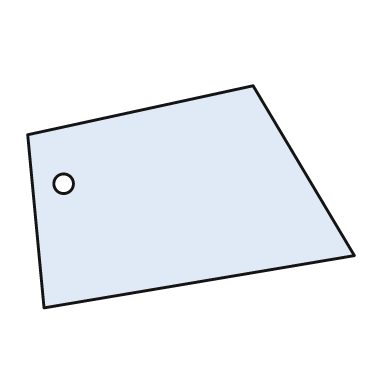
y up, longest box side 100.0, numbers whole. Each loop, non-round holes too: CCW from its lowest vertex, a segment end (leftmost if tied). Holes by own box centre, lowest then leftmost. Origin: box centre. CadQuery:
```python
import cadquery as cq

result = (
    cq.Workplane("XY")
    .moveTo(-45.0, -34.0)
    .lineTo(50.0, -18.0)
    .lineTo(19.0, 34.0)
    .lineTo(-50.0, 19.0)
    .close()
    .moveTo(-39.0, 4.0)
    .circle(3.0)
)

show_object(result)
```